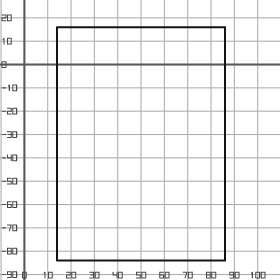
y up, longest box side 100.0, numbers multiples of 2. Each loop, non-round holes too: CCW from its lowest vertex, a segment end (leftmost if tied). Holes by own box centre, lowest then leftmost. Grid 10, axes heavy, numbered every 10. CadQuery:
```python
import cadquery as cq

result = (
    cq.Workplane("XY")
    .moveTo(14.0, -84.0)
    .lineTo(86.0, -84.0)
    .lineTo(86.0, 16.0)
    .lineTo(14.0, 16.0)
    .close()
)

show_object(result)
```